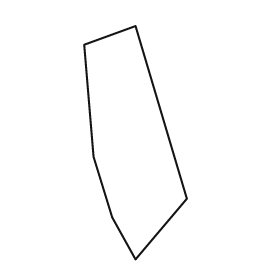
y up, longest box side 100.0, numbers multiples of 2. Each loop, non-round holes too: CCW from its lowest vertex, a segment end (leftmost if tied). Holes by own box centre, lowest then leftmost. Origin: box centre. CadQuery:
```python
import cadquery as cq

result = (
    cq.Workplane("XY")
    .moveTo(0.0, -50.0)
    .lineTo(22.0, -24.0)
    .lineTo(0.0, 50.0)
    .lineTo(-22.0, 42.0)
    .lineTo(-18.0, -6.0)
    .lineTo(-10.0, -32.0)
    .close()
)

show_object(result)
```